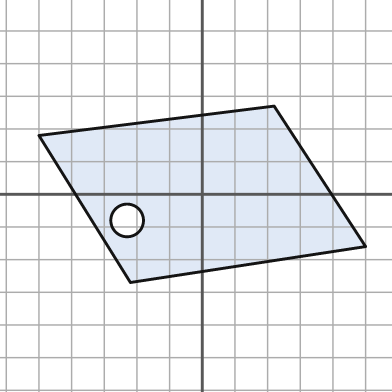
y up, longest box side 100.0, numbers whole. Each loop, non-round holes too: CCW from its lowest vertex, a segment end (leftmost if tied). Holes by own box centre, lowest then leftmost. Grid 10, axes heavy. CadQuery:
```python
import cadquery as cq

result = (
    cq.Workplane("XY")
    .moveTo(-22.0, -27.0)
    .lineTo(50.0, -16.0)
    .lineTo(22.0, 27.0)
    .lineTo(-50.0, 18.0)
    .close()
    .moveTo(-23.0, -8.0)
    .circle(5.0)
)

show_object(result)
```